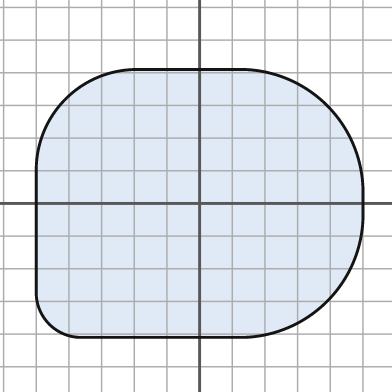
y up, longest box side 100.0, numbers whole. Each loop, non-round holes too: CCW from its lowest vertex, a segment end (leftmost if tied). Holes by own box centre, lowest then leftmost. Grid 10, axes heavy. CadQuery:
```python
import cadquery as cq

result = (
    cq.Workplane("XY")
    .moveTo(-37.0, -41.0)
    .lineTo(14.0, -41.0)
    .threePointArc((39.0, -30.0), (50.0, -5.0))
    .lineTo(50.0, 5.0)
    .threePointArc((39.0, 30.0), (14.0, 41.0))
    .lineTo(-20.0, 41.0)
    .threePointArc((-41.0, 32.0), (-50.0, 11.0))
    .lineTo(-50.0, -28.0)
    .threePointArc((-46.0, -37.0), (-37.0, -41.0))
    .close()
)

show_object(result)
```